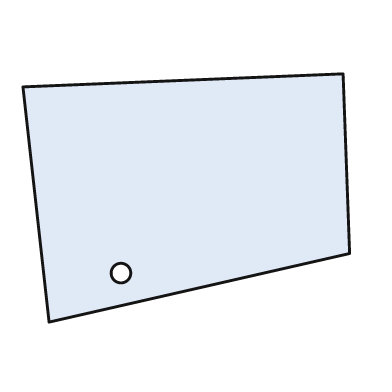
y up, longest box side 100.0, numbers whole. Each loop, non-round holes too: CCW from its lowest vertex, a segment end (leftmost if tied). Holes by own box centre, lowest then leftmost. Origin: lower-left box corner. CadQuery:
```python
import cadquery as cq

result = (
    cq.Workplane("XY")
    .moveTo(8.0, 0.0)
    .lineTo(100.0, 21.0)
    .lineTo(98.0, 76.0)
    .lineTo(0.0, 72.0)
    .close()
    .moveTo(30.0, 15.0)
    .circle(3.0)
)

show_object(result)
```